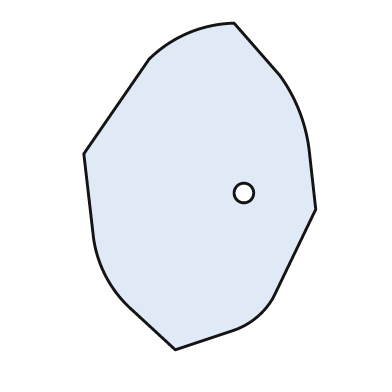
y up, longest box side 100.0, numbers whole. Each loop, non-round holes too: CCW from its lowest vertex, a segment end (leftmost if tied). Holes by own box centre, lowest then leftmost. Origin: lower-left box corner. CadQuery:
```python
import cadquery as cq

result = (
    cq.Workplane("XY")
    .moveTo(28.0, 0.0)
    .lineTo(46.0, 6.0)
    .threePointArc((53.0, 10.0), (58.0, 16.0))
    .lineTo(71.0, 43.0)
    .lineTo(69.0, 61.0)
    .threePointArc((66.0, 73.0), (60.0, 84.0))
    .lineTo(46.0, 100.0)
    .threePointArc((32.0, 97.0), (20.0, 89.0))
    .lineTo(0.0, 60.0)
    .lineTo(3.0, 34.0)
    .threePointArc((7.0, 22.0), (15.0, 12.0))
    .close()
    .moveTo(49.0, 48.0)
    .circle(3.0)
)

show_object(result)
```